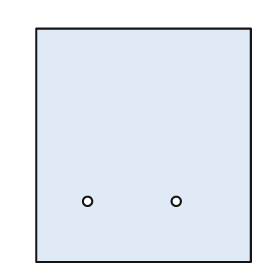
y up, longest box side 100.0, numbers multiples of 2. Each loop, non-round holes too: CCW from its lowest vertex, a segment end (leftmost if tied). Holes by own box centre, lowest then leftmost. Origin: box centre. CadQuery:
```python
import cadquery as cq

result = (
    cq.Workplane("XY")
    .moveTo(-46.0, -50.0)
    .lineTo(46.0, -50.0)
    .lineTo(46.0, 50.0)
    .lineTo(-46.0, 50.0)
    .close()
    .moveTo(-24.0, -24.0)
    .circle(2.0)
    .moveTo(14.0, -24.0)
    .circle(2.0)
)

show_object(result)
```